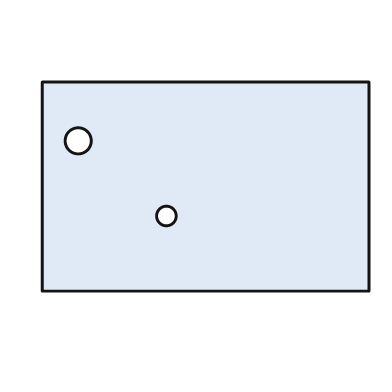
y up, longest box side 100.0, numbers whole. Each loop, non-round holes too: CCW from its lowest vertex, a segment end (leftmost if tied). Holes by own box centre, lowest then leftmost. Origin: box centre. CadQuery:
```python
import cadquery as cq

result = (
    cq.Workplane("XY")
    .moveTo(-50.0, -32.0)
    .lineTo(50.0, -32.0)
    .lineTo(50.0, 32.0)
    .lineTo(-50.0, 32.0)
    .close()
    .moveTo(-12.0, -9.0)
    .circle(3.0)
    .moveTo(-39.0, 14.0)
    .circle(4.0)
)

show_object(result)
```